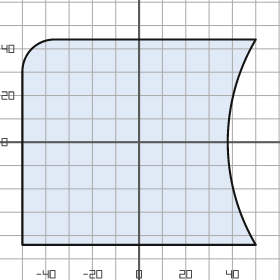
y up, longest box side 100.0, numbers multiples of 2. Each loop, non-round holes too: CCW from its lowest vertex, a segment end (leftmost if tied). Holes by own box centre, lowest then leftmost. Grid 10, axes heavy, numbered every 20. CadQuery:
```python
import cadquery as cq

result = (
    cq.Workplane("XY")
    .moveTo(-50.0, -44.0)
    .lineTo(50.0, -44.0)
    .threePointArc((38.0, 0.0), (50.0, 44.0))
    .lineTo(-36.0, 44.0)
    .threePointArc((-46.0, 40.0), (-50.0, 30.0))
    .close()
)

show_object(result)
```